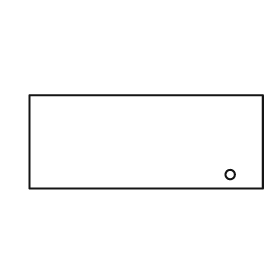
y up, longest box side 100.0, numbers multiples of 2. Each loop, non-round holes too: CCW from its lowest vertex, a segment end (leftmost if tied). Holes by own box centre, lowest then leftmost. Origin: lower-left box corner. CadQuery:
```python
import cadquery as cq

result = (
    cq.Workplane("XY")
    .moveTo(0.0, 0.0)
    .lineTo(100.0, 0.0)
    .lineTo(100.0, 40.0)
    .lineTo(0.0, 40.0)
    .close()
    .moveTo(86.0, 6.0)
    .circle(2.0)
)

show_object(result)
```